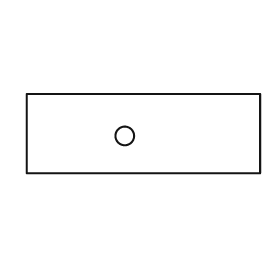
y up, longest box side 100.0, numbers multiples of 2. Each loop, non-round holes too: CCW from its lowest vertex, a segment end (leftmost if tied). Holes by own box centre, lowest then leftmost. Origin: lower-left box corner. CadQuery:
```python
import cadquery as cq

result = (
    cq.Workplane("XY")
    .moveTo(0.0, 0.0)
    .lineTo(100.0, 0.0)
    .lineTo(100.0, 34.0)
    .lineTo(0.0, 34.0)
    .close()
    .moveTo(42.0, 16.0)
    .circle(4.0)
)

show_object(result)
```